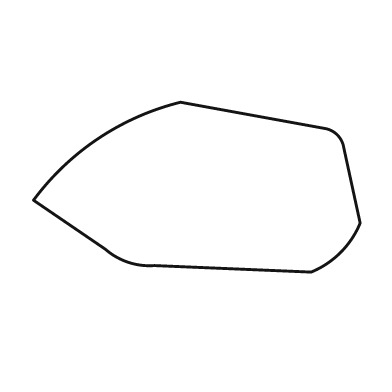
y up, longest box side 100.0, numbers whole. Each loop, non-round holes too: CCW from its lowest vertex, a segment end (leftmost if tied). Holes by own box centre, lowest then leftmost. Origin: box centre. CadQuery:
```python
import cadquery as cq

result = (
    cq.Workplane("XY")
    .moveTo(35.0, -26.0)
    .threePointArc((44.0, -20.0), (50.0, -11.0))
    .lineTo(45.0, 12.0)
    .threePointArc((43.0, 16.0), (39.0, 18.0))
    .lineTo(-5.0, 26.0)
    .threePointArc((-30.0, 15.0), (-50.0, -4.0))
    .lineTo(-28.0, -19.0)
    .threePointArc((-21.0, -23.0), (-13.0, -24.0))
    .close()
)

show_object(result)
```